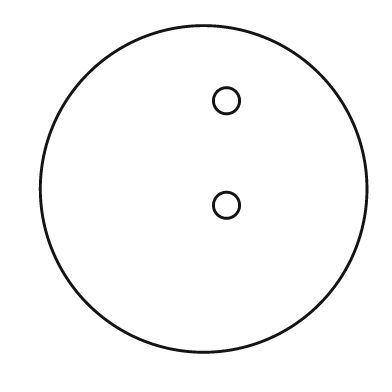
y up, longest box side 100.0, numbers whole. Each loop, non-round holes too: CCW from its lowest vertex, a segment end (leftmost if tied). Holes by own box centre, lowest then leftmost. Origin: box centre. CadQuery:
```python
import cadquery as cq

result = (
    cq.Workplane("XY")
    .moveTo(0.0, 0.0)
    .circle(50.0)
    .moveTo(7.0, -5.0)
    .circle(4.0)
    .moveTo(7.0, 27.0)
    .circle(4.0)
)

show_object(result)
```